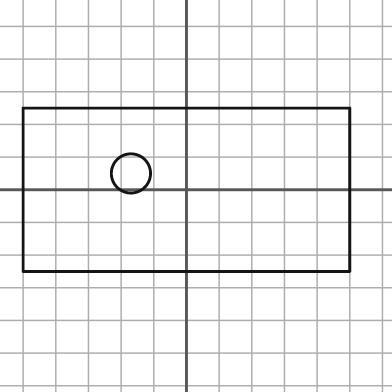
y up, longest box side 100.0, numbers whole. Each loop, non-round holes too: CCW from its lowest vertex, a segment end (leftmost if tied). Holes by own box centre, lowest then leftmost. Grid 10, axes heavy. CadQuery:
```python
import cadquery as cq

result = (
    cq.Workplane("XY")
    .moveTo(-50.0, -25.0)
    .lineTo(50.0, -25.0)
    .lineTo(50.0, 25.0)
    .lineTo(-50.0, 25.0)
    .close()
    .moveTo(-17.0, 5.0)
    .circle(6.0)
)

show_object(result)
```